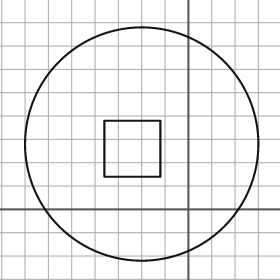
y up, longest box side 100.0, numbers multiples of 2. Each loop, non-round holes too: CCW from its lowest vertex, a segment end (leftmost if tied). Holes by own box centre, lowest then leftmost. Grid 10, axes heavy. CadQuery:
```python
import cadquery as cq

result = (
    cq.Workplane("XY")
    .moveTo(-20.0, 28.0)
    .circle(50.0)
    .moveTo(-36.0, 14.0)
    .lineTo(-12.0, 14.0)
    .lineTo(-12.0, 38.0)
    .lineTo(-36.0, 38.0)
    .close()
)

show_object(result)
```